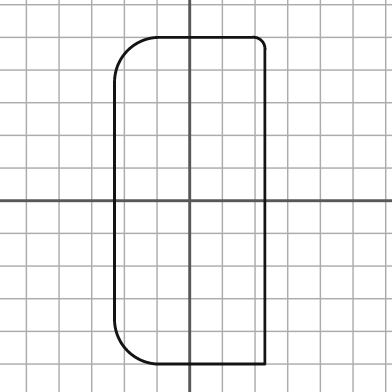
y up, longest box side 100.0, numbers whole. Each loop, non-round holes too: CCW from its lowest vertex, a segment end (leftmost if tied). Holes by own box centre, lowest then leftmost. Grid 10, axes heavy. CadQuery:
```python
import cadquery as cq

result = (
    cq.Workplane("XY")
    .moveTo(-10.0, -50.0)
    .lineTo(23.0, -50.0)
    .lineTo(23.0, 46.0)
    .threePointArc((22.0, 49.0), (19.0, 50.0))
    .lineTo(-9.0, 50.0)
    .threePointArc((-19.0, 46.0), (-23.0, 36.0))
    .lineTo(-23.0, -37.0)
    .threePointArc((-19.0, -46.0), (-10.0, -50.0))
    .close()
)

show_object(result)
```